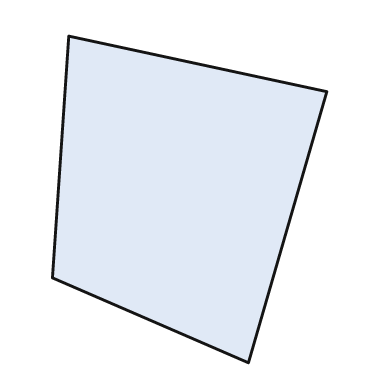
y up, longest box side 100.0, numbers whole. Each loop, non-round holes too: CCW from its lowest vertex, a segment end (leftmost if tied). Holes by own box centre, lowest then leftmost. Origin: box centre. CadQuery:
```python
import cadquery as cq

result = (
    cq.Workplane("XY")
    .moveTo(18.0, -50.0)
    .lineTo(42.0, 33.0)
    .lineTo(-37.0, 50.0)
    .lineTo(-42.0, -24.0)
    .close()
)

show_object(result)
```